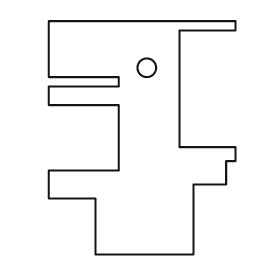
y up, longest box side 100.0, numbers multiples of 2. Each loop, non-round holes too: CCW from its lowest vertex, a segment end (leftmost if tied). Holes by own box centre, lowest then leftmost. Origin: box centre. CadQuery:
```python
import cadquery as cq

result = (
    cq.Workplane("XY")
    .moveTo(-20.0, -50.0)
    .lineTo(22.0, -50.0)
    .lineTo(22.0, -20.0)
    .lineTo(36.0, -20.0)
    .lineTo(36.0, -10.0)
    .lineTo(40.0, -10.0)
    .lineTo(40.0, -4.0)
    .lineTo(16.0, -4.0)
    .lineTo(16.0, 46.0)
    .lineTo(40.0, 46.0)
    .lineTo(40.0, 50.0)
    .lineTo(-40.0, 50.0)
    .lineTo(-40.0, 26.0)
    .lineTo(-10.0, 26.0)
    .lineTo(-10.0, 22.0)
    .lineTo(-40.0, 22.0)
    .lineTo(-40.0, 14.0)
    .lineTo(-10.0, 14.0)
    .lineTo(-10.0, -14.0)
    .lineTo(-40.0, -14.0)
    .lineTo(-40.0, -26.0)
    .lineTo(-20.0, -26.0)
    .close()
    .moveTo(2.0, 30.0)
    .circle(4.0)
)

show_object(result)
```